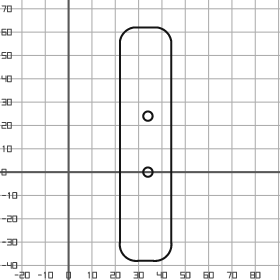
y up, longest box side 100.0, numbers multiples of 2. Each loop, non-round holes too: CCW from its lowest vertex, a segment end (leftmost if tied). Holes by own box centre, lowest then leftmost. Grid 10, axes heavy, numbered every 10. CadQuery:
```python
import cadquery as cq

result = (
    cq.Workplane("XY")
    .moveTo(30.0, -38.0)
    .lineTo(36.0, -38.0)
    .threePointArc((42.0, -36.0), (44.0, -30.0))
    .lineTo(44.0, 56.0)
    .threePointArc((42.0, 60.0), (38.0, 62.0))
    .lineTo(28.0, 62.0)
    .threePointArc((24.0, 60.0), (22.0, 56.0))
    .lineTo(22.0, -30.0)
    .threePointArc((24.0, -36.0), (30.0, -38.0))
    .close()
    .moveTo(34.0, 0.0)
    .circle(2.0)
    .moveTo(34.0, 24.0)
    .circle(2.0)
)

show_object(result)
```